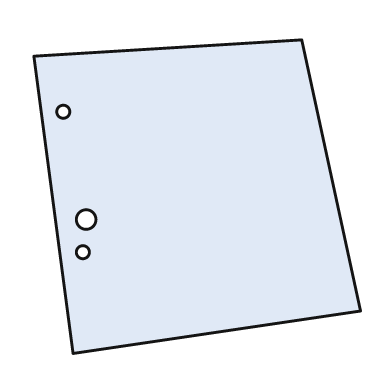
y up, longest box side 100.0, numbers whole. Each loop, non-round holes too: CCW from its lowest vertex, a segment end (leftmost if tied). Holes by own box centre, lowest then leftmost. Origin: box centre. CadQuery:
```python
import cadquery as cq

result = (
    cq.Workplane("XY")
    .moveTo(-38.0, -48.0)
    .lineTo(50.0, -35.0)
    .lineTo(32.0, 48.0)
    .lineTo(-50.0, 43.0)
    .close()
    .moveTo(-35.0, -17.0)
    .circle(2.0)
    .moveTo(-34.0, -7.0)
    .circle(3.0)
    .moveTo(-41.0, 26.0)
    .circle(2.0)
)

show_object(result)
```